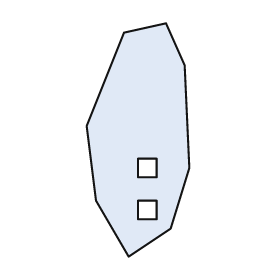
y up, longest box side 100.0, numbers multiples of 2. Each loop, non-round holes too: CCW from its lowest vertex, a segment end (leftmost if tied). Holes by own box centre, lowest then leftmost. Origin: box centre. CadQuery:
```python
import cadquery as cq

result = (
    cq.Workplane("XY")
    .moveTo(-4.0, -50.0)
    .lineTo(14.0, -38.0)
    .lineTo(22.0, -12.0)
    .lineTo(20.0, 32.0)
    .lineTo(12.0, 50.0)
    .lineTo(-6.0, 46.0)
    .lineTo(-22.0, 6.0)
    .lineTo(-18.0, -26.0)
    .close()
    .moveTo(0.0, -34.0)
    .lineTo(8.0, -34.0)
    .lineTo(8.0, -26.0)
    .lineTo(0.0, -26.0)
    .close()
    .moveTo(0.0, -16.0)
    .lineTo(8.0, -16.0)
    .lineTo(8.0, -8.0)
    .lineTo(0.0, -8.0)
    .close()
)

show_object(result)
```